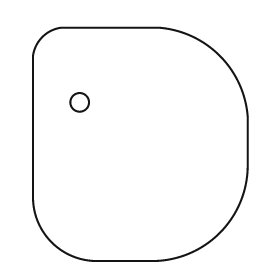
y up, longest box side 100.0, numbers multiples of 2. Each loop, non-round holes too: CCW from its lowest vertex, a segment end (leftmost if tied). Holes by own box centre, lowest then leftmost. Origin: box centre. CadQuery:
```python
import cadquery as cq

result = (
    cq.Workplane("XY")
    .moveTo(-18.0, -50.0)
    .lineTo(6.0, -50.0)
    .threePointArc((34.0, -38.0), (46.0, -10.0))
    .lineTo(46.0, 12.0)
    .threePointArc((34.0, 38.0), (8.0, 50.0))
    .lineTo(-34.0, 50.0)
    .threePointArc((-42.0, 46.0), (-46.0, 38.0))
    .lineTo(-46.0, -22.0)
    .threePointArc((-38.0, -42.0), (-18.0, -50.0))
    .close()
    .moveTo(-26.0, 18.0)
    .circle(4.0)
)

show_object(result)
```